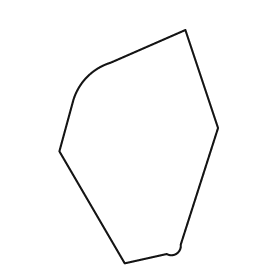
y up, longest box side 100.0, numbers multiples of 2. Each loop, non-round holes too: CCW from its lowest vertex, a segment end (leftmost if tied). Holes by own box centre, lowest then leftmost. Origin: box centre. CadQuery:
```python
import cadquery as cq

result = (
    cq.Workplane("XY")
    .moveTo(-6.0, -50.0)
    .lineTo(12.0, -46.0)
    .threePointArc((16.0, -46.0), (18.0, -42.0))
    .lineTo(34.0, 8.0)
    .lineTo(20.0, 50.0)
    .lineTo(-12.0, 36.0)
    .threePointArc((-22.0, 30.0), (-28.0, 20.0))
    .lineTo(-34.0, -2.0)
    .close()
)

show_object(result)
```